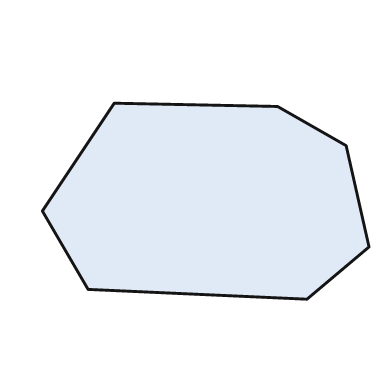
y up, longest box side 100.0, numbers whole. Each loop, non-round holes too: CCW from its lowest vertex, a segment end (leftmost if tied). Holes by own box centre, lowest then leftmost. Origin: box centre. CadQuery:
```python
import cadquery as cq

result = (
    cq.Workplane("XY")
    .moveTo(31.0, -30.0)
    .lineTo(50.0, -14.0)
    .lineTo(43.0, 17.0)
    .lineTo(22.0, 29.0)
    .lineTo(-28.0, 30.0)
    .lineTo(-50.0, -3.0)
    .lineTo(-36.0, -27.0)
    .close()
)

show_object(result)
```